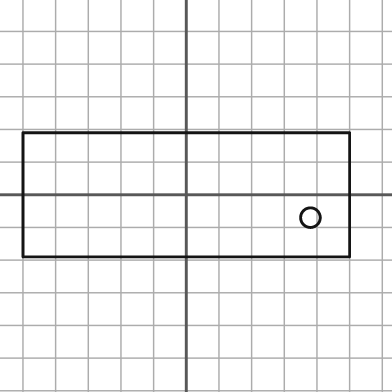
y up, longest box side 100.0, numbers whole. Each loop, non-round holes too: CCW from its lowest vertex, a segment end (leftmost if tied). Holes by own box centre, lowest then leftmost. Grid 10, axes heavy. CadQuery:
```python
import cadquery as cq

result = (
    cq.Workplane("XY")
    .moveTo(-50.0, -19.0)
    .lineTo(50.0, -19.0)
    .lineTo(50.0, 19.0)
    .lineTo(-50.0, 19.0)
    .close()
    .moveTo(38.0, -7.0)
    .circle(3.0)
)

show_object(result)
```